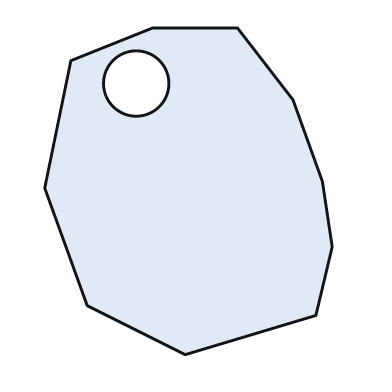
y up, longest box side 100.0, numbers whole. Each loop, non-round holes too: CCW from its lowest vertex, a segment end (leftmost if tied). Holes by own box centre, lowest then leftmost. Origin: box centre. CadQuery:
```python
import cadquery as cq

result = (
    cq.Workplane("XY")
    .moveTo(-1.0, -50.0)
    .lineTo(39.0, -38.0)
    .lineTo(44.0, -17.0)
    .lineTo(41.0, 3.0)
    .lineTo(32.0, 28.0)
    .lineTo(15.0, 50.0)
    .lineTo(-11.0, 50.0)
    .lineTo(-36.0, 40.0)
    .lineTo(-44.0, 1.0)
    .lineTo(-31.0, -35.0)
    .close()
    .moveTo(-16.0, 33.0)
    .circle(10.0)
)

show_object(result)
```